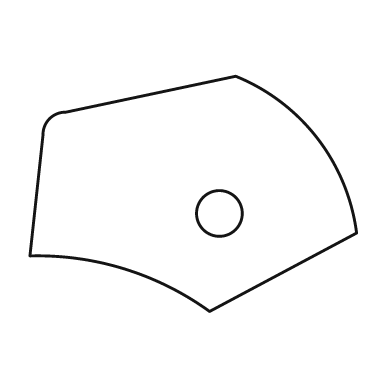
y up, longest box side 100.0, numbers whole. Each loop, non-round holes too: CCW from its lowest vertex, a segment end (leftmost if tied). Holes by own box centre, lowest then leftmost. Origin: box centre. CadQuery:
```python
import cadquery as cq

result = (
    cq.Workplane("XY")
    .moveTo(5.0, -36.0)
    .lineTo(50.0, -12.0)
    .threePointArc((38.0, 17.0), (13.0, 36.0))
    .lineTo(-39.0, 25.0)
    .threePointArc((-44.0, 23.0), (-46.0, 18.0))
    .lineTo(-50.0, -19.0)
    .threePointArc((-21.0, -23.0), (5.0, -36.0))
    .close()
    .moveTo(8.0, -6.0)
    .circle(7.0)
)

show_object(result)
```